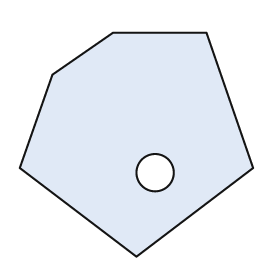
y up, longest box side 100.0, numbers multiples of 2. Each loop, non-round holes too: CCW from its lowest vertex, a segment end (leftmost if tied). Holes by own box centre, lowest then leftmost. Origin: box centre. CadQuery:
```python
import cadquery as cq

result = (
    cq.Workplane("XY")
    .moveTo(0.0, -48.0)
    .lineTo(50.0, -10.0)
    .lineTo(30.0, 48.0)
    .lineTo(-10.0, 48.0)
    .lineTo(-36.0, 30.0)
    .lineTo(-50.0, -10.0)
    .close()
    .moveTo(8.0, -12.0)
    .circle(8.0)
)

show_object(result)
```